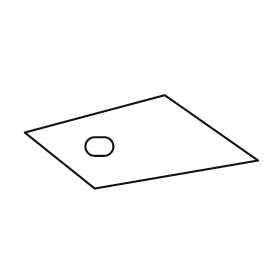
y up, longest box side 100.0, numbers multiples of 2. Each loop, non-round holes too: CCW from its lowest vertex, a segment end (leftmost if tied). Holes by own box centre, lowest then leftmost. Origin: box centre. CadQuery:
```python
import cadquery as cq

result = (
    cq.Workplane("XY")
    .moveTo(-20.0, -20.0)
    .lineTo(50.0, -8.0)
    .lineTo(10.0, 20.0)
    .lineTo(-50.0, 4.0)
    .close()
    .moveTo(-20.0, -6.0)
    .lineTo(-16.0, -6.0)
    .threePointArc((-12.0, -2.0), (-16.0, 2.0))
    .lineTo(-20.0, 2.0)
    .threePointArc((-24.0, -2.0), (-20.0, -6.0))
    .close()
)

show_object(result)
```